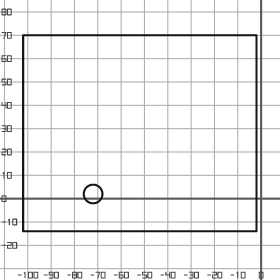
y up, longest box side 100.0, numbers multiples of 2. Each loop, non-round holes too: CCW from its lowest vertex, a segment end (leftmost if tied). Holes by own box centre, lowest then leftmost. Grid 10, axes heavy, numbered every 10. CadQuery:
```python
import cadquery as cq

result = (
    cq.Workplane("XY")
    .moveTo(-102.0, -14.0)
    .lineTo(-2.0, -14.0)
    .lineTo(-2.0, 70.0)
    .lineTo(-102.0, 70.0)
    .close()
    .moveTo(-72.0, 2.0)
    .circle(4.0)
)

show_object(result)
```